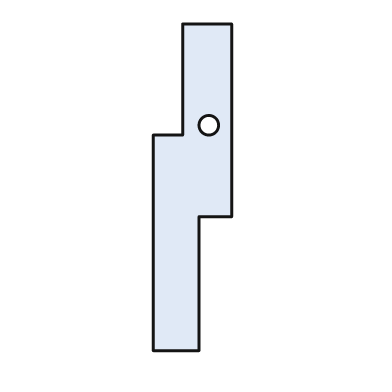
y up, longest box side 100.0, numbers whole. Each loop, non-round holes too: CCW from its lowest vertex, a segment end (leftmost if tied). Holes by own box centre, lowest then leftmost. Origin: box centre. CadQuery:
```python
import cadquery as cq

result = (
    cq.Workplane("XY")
    .moveTo(-12.0, -50.0)
    .lineTo(2.0, -50.0)
    .lineTo(2.0, -9.0)
    .lineTo(12.0, -9.0)
    .lineTo(12.0, 50.0)
    .lineTo(-3.0, 50.0)
    .lineTo(-3.0, 16.0)
    .lineTo(-12.0, 16.0)
    .close()
    .moveTo(5.0, 19.0)
    .circle(3.0)
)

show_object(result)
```